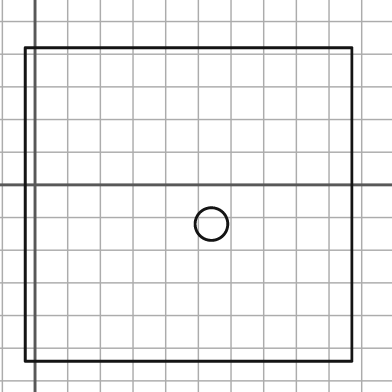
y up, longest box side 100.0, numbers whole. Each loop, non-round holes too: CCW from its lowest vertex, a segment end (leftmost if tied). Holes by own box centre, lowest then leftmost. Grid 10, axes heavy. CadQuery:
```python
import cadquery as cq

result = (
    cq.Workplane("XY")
    .moveTo(-3.0, -54.0)
    .lineTo(97.0, -54.0)
    .lineTo(97.0, 42.0)
    .lineTo(-3.0, 42.0)
    .close()
    .moveTo(54.0, -12.0)
    .circle(5.0)
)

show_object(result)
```